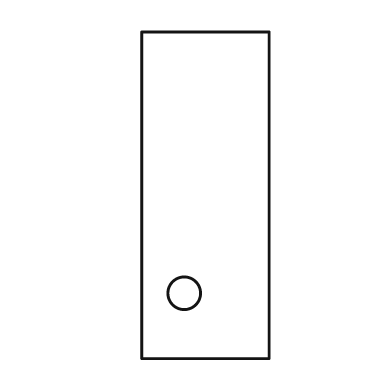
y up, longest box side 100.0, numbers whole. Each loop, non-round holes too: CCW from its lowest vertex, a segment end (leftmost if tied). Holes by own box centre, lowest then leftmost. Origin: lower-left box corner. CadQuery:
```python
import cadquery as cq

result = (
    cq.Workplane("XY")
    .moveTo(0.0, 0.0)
    .lineTo(39.0, 0.0)
    .lineTo(39.0, 100.0)
    .lineTo(0.0, 100.0)
    .close()
    .moveTo(13.0, 20.0)
    .circle(5.0)
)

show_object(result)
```